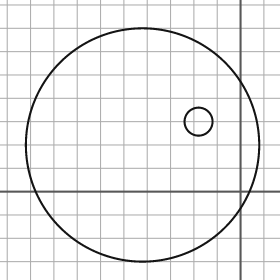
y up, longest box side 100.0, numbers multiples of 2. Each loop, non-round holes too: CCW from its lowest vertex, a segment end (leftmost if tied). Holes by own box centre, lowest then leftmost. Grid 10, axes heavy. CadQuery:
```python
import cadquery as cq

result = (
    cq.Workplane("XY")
    .moveTo(-42.0, 20.0)
    .circle(50.0)
    .moveTo(-18.0, 30.0)
    .circle(6.0)
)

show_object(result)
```